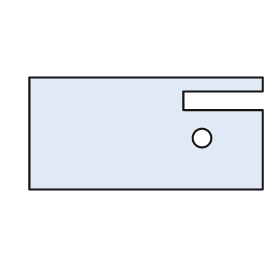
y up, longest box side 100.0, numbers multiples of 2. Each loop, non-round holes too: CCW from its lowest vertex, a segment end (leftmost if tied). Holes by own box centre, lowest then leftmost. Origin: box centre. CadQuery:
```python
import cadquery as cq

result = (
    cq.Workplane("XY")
    .moveTo(-50.0, -24.0)
    .lineTo(50.0, -24.0)
    .lineTo(50.0, 10.0)
    .lineTo(16.0, 10.0)
    .lineTo(16.0, 18.0)
    .lineTo(50.0, 18.0)
    .lineTo(50.0, 24.0)
    .lineTo(-50.0, 24.0)
    .close()
    .moveTo(24.0, -2.0)
    .circle(4.0)
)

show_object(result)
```